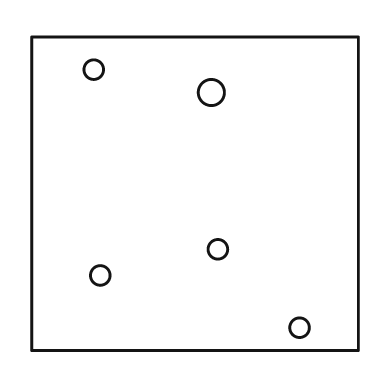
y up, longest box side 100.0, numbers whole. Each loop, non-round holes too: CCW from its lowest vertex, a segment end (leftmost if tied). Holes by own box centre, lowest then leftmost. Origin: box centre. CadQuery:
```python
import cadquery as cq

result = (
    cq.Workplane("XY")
    .moveTo(-50.0, -48.0)
    .lineTo(50.0, -48.0)
    .lineTo(50.0, 48.0)
    .lineTo(-50.0, 48.0)
    .close()
    .moveTo(32.0, -41.0)
    .circle(3.0)
    .moveTo(-29.0, -25.0)
    .circle(3.0)
    .moveTo(7.0, -17.0)
    .circle(3.0)
    .moveTo(5.0, 31.0)
    .circle(4.0)
    .moveTo(-31.0, 38.0)
    .circle(3.0)
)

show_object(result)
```